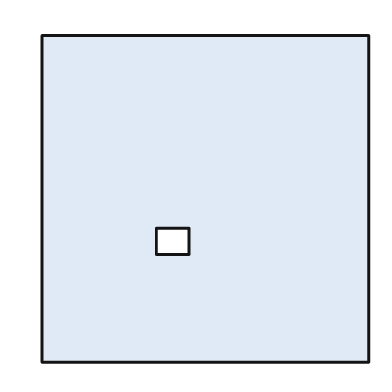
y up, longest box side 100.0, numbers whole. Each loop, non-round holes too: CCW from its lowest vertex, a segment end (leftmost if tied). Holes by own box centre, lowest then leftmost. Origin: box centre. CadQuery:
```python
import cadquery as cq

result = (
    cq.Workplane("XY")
    .moveTo(-50.0, -50.0)
    .lineTo(50.0, -50.0)
    .lineTo(50.0, 50.0)
    .lineTo(-50.0, 50.0)
    .close()
    .moveTo(-15.0, -17.0)
    .lineTo(-5.0, -17.0)
    .lineTo(-5.0, -9.0)
    .lineTo(-15.0, -9.0)
    .close()
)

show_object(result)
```